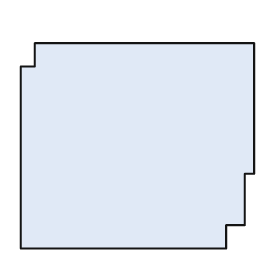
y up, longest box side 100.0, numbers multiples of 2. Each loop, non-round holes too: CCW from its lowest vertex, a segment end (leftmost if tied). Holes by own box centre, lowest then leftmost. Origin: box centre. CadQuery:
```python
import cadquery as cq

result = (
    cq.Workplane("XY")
    .moveTo(-50.0, -44.0)
    .lineTo(38.0, -44.0)
    .lineTo(38.0, -34.0)
    .lineTo(46.0, -34.0)
    .lineTo(46.0, -12.0)
    .lineTo(50.0, -12.0)
    .lineTo(50.0, 44.0)
    .lineTo(-44.0, 44.0)
    .lineTo(-44.0, 34.0)
    .lineTo(-50.0, 34.0)
    .close()
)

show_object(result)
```